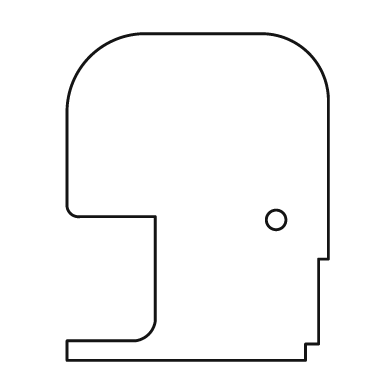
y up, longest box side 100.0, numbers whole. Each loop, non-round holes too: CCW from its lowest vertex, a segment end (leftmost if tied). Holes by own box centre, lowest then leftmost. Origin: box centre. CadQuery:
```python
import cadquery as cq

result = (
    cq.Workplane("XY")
    .moveTo(-40.0, -50.0)
    .lineTo(33.0, -50.0)
    .lineTo(33.0, -45.0)
    .lineTo(37.0, -45.0)
    .lineTo(37.0, -19.0)
    .lineTo(40.0, -19.0)
    .lineTo(40.0, 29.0)
    .threePointArc((34.0, 44.0), (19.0, 50.0))
    .lineTo(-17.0, 50.0)
    .threePointArc((-33.0, 43.0), (-40.0, 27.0))
    .lineTo(-40.0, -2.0)
    .threePointArc((-39.0, -5.0), (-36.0, -6.0))
    .lineTo(-13.0, -6.0)
    .lineTo(-13.0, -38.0)
    .threePointArc((-15.0, -42.0), (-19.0, -44.0))
    .lineTo(-40.0, -44.0)
    .close()
    .moveTo(24.0, -7.0)
    .circle(3.0)
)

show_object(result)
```